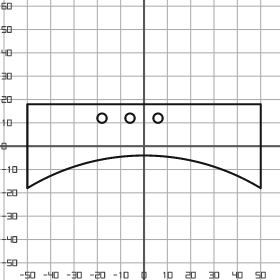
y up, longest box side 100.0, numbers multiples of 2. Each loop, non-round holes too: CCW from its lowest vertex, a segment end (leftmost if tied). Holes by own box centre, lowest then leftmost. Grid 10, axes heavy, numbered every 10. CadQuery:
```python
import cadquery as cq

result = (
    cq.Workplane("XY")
    .moveTo(-50.0, -18.0)
    .threePointArc((0.0, -4.0), (50.0, -18.0))
    .lineTo(50.0, 18.0)
    .lineTo(-50.0, 18.0)
    .close()
    .moveTo(-18.0, 12.0)
    .circle(2.0)
    .moveTo(-6.0, 12.0)
    .circle(2.0)
    .moveTo(6.0, 12.0)
    .circle(2.0)
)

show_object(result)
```